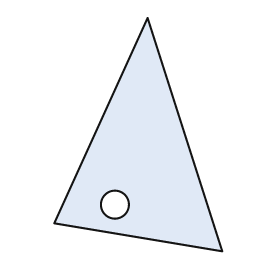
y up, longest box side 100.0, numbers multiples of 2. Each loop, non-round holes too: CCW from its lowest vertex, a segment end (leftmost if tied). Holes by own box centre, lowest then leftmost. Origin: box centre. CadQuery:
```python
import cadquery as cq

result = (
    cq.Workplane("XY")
    .moveTo(36.0, -50.0)
    .lineTo(4.0, 50.0)
    .lineTo(-36.0, -38.0)
    .close()
    .moveTo(-10.0, -30.0)
    .circle(6.0)
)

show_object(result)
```